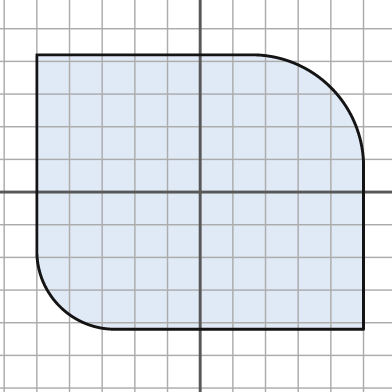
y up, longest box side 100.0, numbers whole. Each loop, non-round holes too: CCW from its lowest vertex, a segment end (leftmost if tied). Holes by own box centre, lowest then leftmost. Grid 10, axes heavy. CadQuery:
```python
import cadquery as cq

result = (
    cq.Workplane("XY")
    .moveTo(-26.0, -42.0)
    .lineTo(50.0, -42.0)
    .lineTo(50.0, 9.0)
    .threePointArc((40.0, 32.0), (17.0, 42.0))
    .lineTo(-50.0, 42.0)
    .lineTo(-50.0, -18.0)
    .threePointArc((-43.0, -35.0), (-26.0, -42.0))
    .close()
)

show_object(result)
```